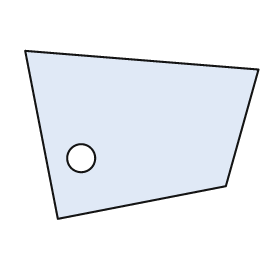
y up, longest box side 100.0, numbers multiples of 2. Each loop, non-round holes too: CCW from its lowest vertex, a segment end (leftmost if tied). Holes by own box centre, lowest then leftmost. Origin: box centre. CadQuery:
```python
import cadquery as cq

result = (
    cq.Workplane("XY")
    .moveTo(-36.0, -36.0)
    .lineTo(36.0, -22.0)
    .lineTo(50.0, 28.0)
    .lineTo(-50.0, 36.0)
    .close()
    .moveTo(-26.0, -10.0)
    .circle(6.0)
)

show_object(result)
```